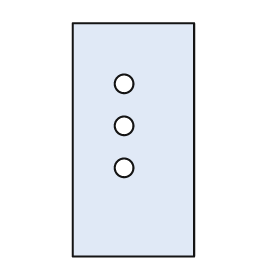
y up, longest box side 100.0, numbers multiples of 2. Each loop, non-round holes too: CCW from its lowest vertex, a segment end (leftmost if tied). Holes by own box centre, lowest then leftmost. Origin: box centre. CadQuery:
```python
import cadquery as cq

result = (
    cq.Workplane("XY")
    .moveTo(-26.0, -50.0)
    .lineTo(26.0, -50.0)
    .lineTo(26.0, 50.0)
    .lineTo(-26.0, 50.0)
    .close()
    .moveTo(-4.0, -12.0)
    .circle(4.0)
    .moveTo(-4.0, 6.0)
    .circle(4.0)
    .moveTo(-4.0, 24.0)
    .circle(4.0)
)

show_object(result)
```